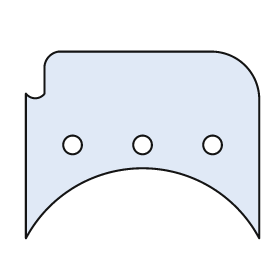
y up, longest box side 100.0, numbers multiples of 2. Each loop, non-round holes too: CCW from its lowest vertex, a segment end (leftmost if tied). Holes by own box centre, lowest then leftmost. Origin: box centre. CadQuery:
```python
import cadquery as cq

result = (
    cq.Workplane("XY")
    .moveTo(-50.0, -40.0)
    .threePointArc((0.0, -10.0), (50.0, -40.0))
    .lineTo(50.0, 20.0)
    .threePointArc((44.0, 34.0), (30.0, 40.0))
    .lineTo(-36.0, 40.0)
    .threePointArc((-40.0, 38.0), (-42.0, 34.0))
    .lineTo(-42.0, 22.0)
    .threePointArc((-46.0, 20.0), (-50.0, 22.0))
    .close()
    .moveTo(-30.0, 0.0)
    .circle(4.0)
    .moveTo(0.0, 0.0)
    .circle(4.0)
    .moveTo(30.0, 0.0)
    .circle(4.0)
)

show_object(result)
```